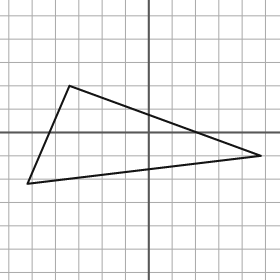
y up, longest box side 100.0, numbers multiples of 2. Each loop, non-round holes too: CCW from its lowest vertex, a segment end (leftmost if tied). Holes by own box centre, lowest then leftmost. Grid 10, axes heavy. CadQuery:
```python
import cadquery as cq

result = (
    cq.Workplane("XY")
    .moveTo(-52.0, -22.0)
    .lineTo(48.0, -10.0)
    .lineTo(-34.0, 20.0)
    .close()
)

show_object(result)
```